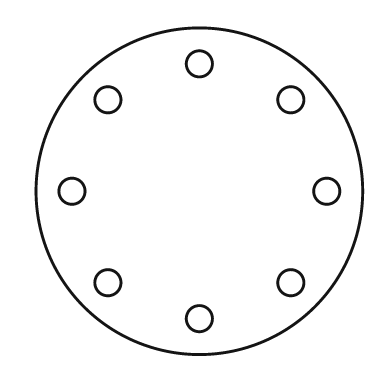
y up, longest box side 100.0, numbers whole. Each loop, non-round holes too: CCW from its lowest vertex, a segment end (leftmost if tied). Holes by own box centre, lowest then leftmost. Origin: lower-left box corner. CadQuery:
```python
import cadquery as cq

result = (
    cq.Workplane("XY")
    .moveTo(50.0, 50.0)
    .circle(50.0)
    .moveTo(50.0, 11.0)
    .circle(4.0)
    .moveTo(22.0, 22.0)
    .circle(4.0)
    .moveTo(78.0, 22.0)
    .circle(4.0)
    .moveTo(11.0, 50.0)
    .circle(4.0)
    .moveTo(89.0, 50.0)
    .circle(4.0)
    .moveTo(22.0, 78.0)
    .circle(4.0)
    .moveTo(78.0, 78.0)
    .circle(4.0)
    .moveTo(50.0, 89.0)
    .circle(4.0)
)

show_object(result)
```